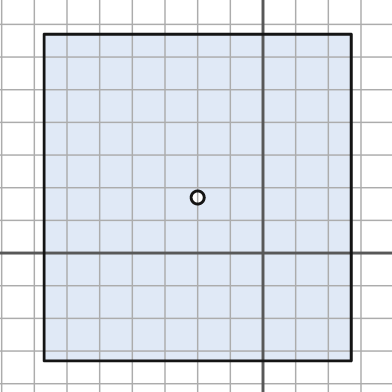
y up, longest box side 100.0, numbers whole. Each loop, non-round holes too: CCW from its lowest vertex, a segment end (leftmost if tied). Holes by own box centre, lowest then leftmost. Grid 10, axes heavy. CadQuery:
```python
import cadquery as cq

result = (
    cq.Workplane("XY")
    .moveTo(-67.0, -33.0)
    .lineTo(27.0, -33.0)
    .lineTo(27.0, 67.0)
    .lineTo(-67.0, 67.0)
    .close()
    .moveTo(-20.0, 17.0)
    .circle(2.0)
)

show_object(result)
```